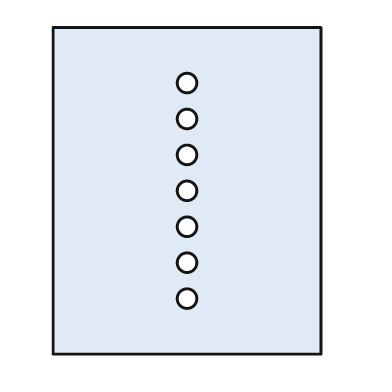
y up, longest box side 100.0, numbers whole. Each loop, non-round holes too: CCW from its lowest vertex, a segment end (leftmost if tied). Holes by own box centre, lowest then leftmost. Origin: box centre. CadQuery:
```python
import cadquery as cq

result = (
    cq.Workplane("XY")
    .moveTo(-41.0, -50.0)
    .lineTo(41.0, -50.0)
    .lineTo(41.0, 50.0)
    .lineTo(-41.0, 50.0)
    .close()
    .moveTo(0.0, -33.0)
    .circle(3.0)
    .moveTo(0.0, -22.0)
    .circle(3.0)
    .moveTo(0.0, -11.0)
    .circle(3.0)
    .moveTo(0.0, 0.0)
    .circle(3.0)
    .moveTo(0.0, 11.0)
    .circle(3.0)
    .moveTo(0.0, 22.0)
    .circle(3.0)
    .moveTo(0.0, 33.0)
    .circle(3.0)
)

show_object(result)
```